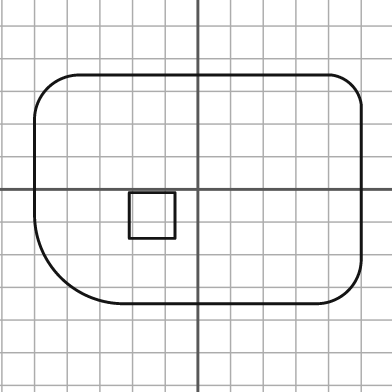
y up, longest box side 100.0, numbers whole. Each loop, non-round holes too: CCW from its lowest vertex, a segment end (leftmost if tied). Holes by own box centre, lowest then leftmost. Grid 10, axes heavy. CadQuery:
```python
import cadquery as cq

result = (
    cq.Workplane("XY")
    .moveTo(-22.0, -35.0)
    .lineTo(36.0, -35.0)
    .threePointArc((46.0, -31.0), (50.0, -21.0))
    .lineTo(50.0, 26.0)
    .threePointArc((47.0, 32.0), (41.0, 35.0))
    .lineTo(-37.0, 35.0)
    .threePointArc((-46.0, 31.0), (-50.0, 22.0))
    .lineTo(-50.0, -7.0)
    .threePointArc((-42.0, -27.0), (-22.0, -35.0))
    .close()
    .moveTo(-21.0, -15.0)
    .lineTo(-7.0, -15.0)
    .lineTo(-7.0, -1.0)
    .lineTo(-21.0, -1.0)
    .close()
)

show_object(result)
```